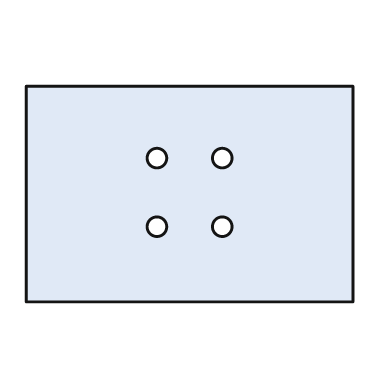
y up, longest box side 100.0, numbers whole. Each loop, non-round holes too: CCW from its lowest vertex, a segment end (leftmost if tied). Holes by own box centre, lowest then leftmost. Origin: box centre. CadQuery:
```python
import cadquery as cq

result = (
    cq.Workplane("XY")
    .moveTo(-50.0, -33.0)
    .lineTo(50.0, -33.0)
    .lineTo(50.0, 33.0)
    .lineTo(-50.0, 33.0)
    .close()
    .moveTo(-10.0, -10.0)
    .circle(3.0)
    .moveTo(10.0, -10.0)
    .circle(3.0)
    .moveTo(-10.0, 11.0)
    .circle(3.0)
    .moveTo(10.0, 11.0)
    .circle(3.0)
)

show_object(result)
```